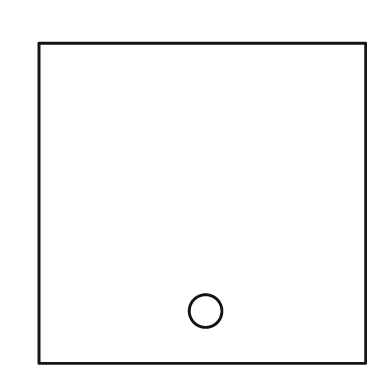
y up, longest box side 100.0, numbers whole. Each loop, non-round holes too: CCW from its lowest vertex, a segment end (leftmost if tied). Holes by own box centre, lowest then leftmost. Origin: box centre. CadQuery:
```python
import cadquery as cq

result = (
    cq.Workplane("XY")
    .moveTo(-50.0, -49.0)
    .lineTo(50.0, -49.0)
    .lineTo(50.0, 49.0)
    .lineTo(-50.0, 49.0)
    .close()
    .moveTo(1.0, -33.0)
    .circle(5.0)
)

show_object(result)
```